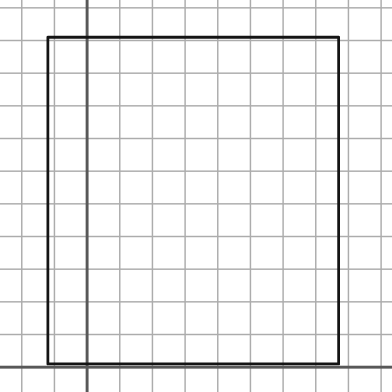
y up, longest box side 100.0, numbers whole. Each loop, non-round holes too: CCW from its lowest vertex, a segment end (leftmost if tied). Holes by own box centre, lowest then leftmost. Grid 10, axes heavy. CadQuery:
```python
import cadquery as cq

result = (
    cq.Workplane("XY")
    .moveTo(-12.0, 1.0)
    .lineTo(77.0, 1.0)
    .lineTo(77.0, 101.0)
    .lineTo(-12.0, 101.0)
    .close()
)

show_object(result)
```